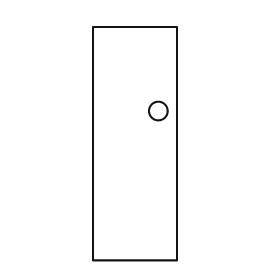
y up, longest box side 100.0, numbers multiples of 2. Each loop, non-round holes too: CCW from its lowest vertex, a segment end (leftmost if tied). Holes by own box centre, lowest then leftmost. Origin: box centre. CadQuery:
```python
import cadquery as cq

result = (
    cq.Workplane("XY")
    .moveTo(-18.0, -50.0)
    .lineTo(18.0, -50.0)
    .lineTo(18.0, 50.0)
    .lineTo(-18.0, 50.0)
    .close()
    .moveTo(10.0, 14.0)
    .circle(4.0)
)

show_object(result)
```